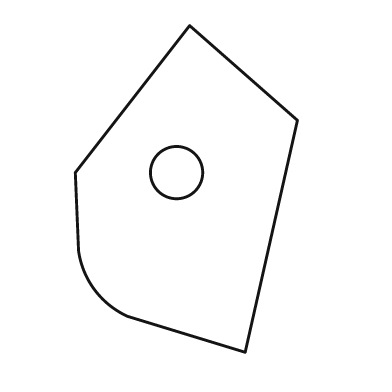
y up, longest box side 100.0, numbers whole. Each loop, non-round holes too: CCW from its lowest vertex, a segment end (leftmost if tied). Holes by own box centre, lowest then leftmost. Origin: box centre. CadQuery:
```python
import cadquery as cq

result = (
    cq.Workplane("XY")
    .moveTo(18.0, -50.0)
    .lineTo(34.0, 21.0)
    .lineTo(1.0, 50.0)
    .lineTo(-34.0, 5.0)
    .lineTo(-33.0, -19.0)
    .threePointArc((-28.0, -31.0), (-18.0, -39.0))
    .close()
    .moveTo(-3.0, 5.0)
    .circle(8.0)
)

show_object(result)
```